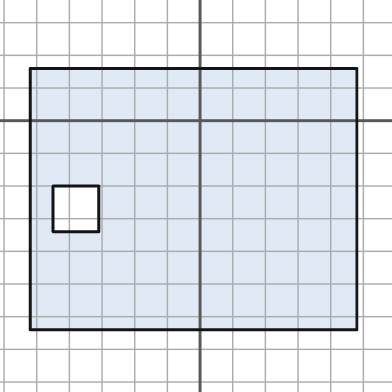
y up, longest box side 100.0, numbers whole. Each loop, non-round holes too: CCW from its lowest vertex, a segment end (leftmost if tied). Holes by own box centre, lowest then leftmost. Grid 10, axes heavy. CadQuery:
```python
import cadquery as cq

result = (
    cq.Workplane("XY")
    .moveTo(-52.0, -64.0)
    .lineTo(48.0, -64.0)
    .lineTo(48.0, 16.0)
    .lineTo(-52.0, 16.0)
    .close()
    .moveTo(-45.0, -34.0)
    .lineTo(-31.0, -34.0)
    .lineTo(-31.0, -20.0)
    .lineTo(-45.0, -20.0)
    .close()
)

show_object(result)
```